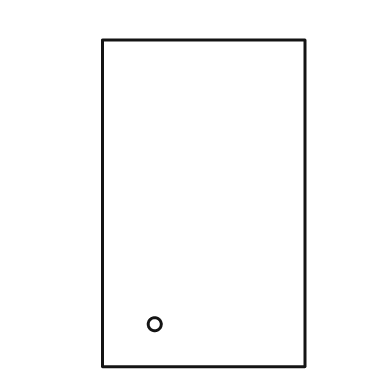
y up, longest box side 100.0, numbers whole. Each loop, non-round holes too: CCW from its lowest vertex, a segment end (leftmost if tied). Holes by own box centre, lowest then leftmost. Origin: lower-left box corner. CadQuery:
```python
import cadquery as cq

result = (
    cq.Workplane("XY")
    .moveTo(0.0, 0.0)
    .lineTo(62.0, 0.0)
    .lineTo(62.0, 100.0)
    .lineTo(0.0, 100.0)
    .close()
    .moveTo(16.0, 13.0)
    .circle(2.0)
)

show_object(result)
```